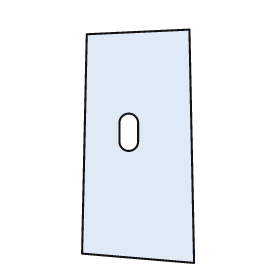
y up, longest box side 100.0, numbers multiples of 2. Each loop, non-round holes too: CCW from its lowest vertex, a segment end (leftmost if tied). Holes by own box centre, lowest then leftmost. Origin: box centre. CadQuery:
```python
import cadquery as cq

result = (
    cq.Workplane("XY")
    .moveTo(24.0, -50.0)
    .lineTo(22.0, 50.0)
    .lineTo(-22.0, 48.0)
    .lineTo(-24.0, -46.0)
    .close()
    .moveTo(-8.0, 2.0)
    .threePointArc((-4.0, -2.0), (0.0, 2.0))
    .lineTo(0.0, 10.0)
    .threePointArc((-4.0, 14.0), (-8.0, 10.0))
    .close()
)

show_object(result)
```